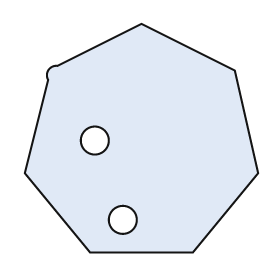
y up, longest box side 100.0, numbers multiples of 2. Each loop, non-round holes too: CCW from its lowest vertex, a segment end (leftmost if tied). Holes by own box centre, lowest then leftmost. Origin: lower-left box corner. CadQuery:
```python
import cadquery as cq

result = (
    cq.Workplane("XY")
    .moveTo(28.0, 0.0)
    .lineTo(72.0, 0.0)
    .lineTo(100.0, 34.0)
    .lineTo(90.0, 78.0)
    .lineTo(50.0, 98.0)
    .lineTo(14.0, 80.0)
    .threePointArc((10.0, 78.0), (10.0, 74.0))
    .lineTo(0.0, 34.0)
    .close()
    .moveTo(42.0, 14.0)
    .circle(6.0)
    .moveTo(30.0, 48.0)
    .circle(6.0)
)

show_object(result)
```